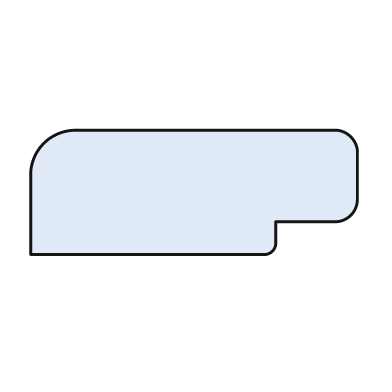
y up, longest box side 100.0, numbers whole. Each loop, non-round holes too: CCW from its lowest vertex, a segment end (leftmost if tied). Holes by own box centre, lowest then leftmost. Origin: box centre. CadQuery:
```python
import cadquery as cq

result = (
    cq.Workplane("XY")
    .moveTo(-50.0, -19.0)
    .lineTo(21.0, -19.0)
    .threePointArc((24.0, -18.0), (25.0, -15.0))
    .lineTo(25.0, -9.0)
    .lineTo(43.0, -9.0)
    .threePointArc((48.0, -7.0), (50.0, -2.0))
    .lineTo(50.0, 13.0)
    .threePointArc((48.0, 17.0), (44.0, 19.0))
    .lineTo(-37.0, 19.0)
    .threePointArc((-46.0, 15.0), (-50.0, 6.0))
    .close()
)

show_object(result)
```